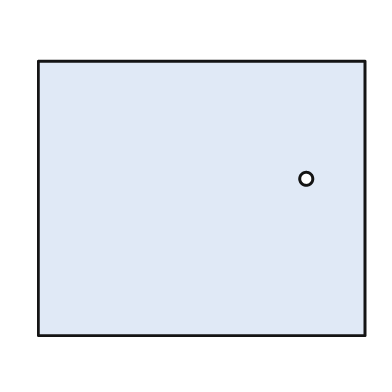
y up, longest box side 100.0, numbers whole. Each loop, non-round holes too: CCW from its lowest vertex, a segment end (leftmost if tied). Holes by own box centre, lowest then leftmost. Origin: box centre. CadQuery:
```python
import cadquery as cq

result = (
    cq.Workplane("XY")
    .moveTo(-50.0, -42.0)
    .lineTo(50.0, -42.0)
    .lineTo(50.0, 42.0)
    .lineTo(-50.0, 42.0)
    .close()
    .moveTo(32.0, 6.0)
    .circle(2.0)
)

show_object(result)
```